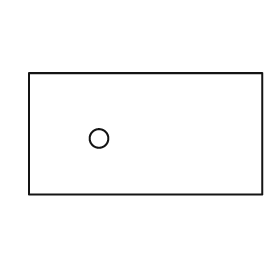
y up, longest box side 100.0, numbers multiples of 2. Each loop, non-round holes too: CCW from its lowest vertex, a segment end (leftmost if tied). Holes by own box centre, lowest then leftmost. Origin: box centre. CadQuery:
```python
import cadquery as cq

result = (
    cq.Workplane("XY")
    .moveTo(-50.0, -26.0)
    .lineTo(50.0, -26.0)
    .lineTo(50.0, 26.0)
    .lineTo(-50.0, 26.0)
    .close()
    .moveTo(-20.0, -2.0)
    .circle(4.0)
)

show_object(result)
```